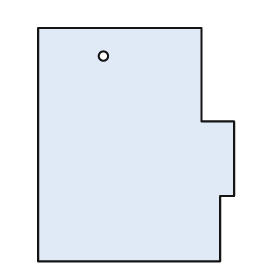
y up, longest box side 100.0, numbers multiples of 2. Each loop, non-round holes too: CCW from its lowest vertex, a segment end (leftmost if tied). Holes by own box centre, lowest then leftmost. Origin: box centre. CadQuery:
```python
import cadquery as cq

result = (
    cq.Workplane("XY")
    .moveTo(-42.0, -50.0)
    .lineTo(36.0, -50.0)
    .lineTo(36.0, -22.0)
    .lineTo(42.0, -22.0)
    .lineTo(42.0, 10.0)
    .lineTo(28.0, 10.0)
    .lineTo(28.0, 50.0)
    .lineTo(-42.0, 50.0)
    .close()
    .moveTo(-14.0, 38.0)
    .circle(2.0)
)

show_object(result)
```